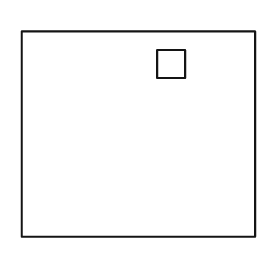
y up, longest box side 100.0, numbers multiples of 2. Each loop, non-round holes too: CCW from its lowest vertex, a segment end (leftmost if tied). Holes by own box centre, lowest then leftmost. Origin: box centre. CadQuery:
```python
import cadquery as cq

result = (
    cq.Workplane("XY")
    .moveTo(-50.0, -44.0)
    .lineTo(50.0, -44.0)
    .lineTo(50.0, 44.0)
    .lineTo(-50.0, 44.0)
    .close()
    .moveTo(8.0, 24.0)
    .lineTo(20.0, 24.0)
    .lineTo(20.0, 36.0)
    .lineTo(8.0, 36.0)
    .close()
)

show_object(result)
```